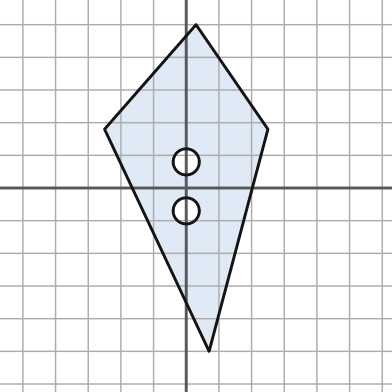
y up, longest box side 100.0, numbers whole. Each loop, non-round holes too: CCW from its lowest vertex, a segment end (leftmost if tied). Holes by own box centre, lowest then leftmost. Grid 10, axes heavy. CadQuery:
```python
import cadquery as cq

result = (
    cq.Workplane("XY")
    .moveTo(7.0, -50.0)
    .lineTo(25.0, 18.0)
    .lineTo(3.0, 50.0)
    .lineTo(-25.0, 18.0)
    .close()
    .moveTo(0.0, -7.0)
    .circle(4.0)
    .moveTo(0.0, 8.0)
    .circle(4.0)
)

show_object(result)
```